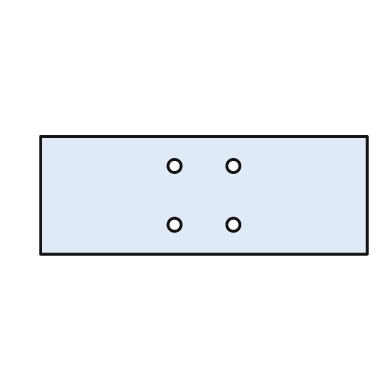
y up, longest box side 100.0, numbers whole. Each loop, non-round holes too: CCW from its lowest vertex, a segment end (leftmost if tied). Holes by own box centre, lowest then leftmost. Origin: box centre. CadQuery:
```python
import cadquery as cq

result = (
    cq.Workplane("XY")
    .moveTo(-50.0, -18.0)
    .lineTo(50.0, -18.0)
    .lineTo(50.0, 18.0)
    .lineTo(-50.0, 18.0)
    .close()
    .moveTo(-9.0, -9.0)
    .circle(2.0)
    .moveTo(9.0, -9.0)
    .circle(2.0)
    .moveTo(-9.0, 9.0)
    .circle(2.0)
    .moveTo(9.0, 9.0)
    .circle(2.0)
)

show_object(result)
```